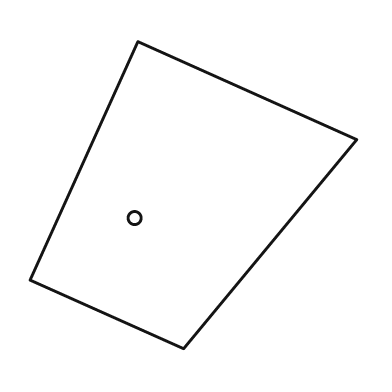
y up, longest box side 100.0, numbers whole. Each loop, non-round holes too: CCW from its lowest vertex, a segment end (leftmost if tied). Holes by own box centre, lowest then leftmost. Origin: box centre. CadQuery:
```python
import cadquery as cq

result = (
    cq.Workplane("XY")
    .moveTo(-3.0, -47.0)
    .lineTo(50.0, 17.0)
    .lineTo(-17.0, 47.0)
    .lineTo(-50.0, -26.0)
    .close()
    .moveTo(-18.0, -7.0)
    .circle(2.0)
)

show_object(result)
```